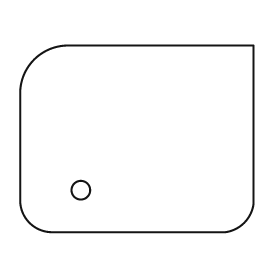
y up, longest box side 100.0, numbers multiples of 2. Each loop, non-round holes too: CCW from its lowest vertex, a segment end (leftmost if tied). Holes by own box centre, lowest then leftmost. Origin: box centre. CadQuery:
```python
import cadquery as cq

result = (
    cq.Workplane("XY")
    .moveTo(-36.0, -40.0)
    .lineTo(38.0, -40.0)
    .threePointArc((46.0, -36.0), (50.0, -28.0))
    .lineTo(50.0, 40.0)
    .lineTo(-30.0, 40.0)
    .threePointArc((-44.0, 34.0), (-50.0, 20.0))
    .lineTo(-50.0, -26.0)
    .threePointArc((-46.0, -36.0), (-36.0, -40.0))
    .close()
    .moveTo(-24.0, -22.0)
    .circle(4.0)
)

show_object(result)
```